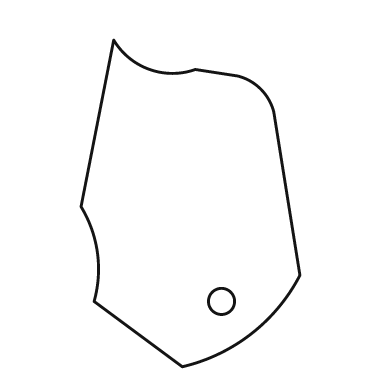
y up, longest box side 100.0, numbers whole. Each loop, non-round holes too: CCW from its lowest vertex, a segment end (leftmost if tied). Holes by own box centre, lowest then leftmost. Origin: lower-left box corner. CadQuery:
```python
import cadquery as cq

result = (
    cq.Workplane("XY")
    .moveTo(31.0, 0.0)
    .threePointArc((52.0, 10.0), (67.0, 28.0))
    .lineTo(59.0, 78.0)
    .threePointArc((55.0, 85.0), (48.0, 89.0))
    .lineTo(35.0, 91.0)
    .threePointArc((21.0, 91.0), (10.0, 100.0))
    .lineTo(0.0, 49.0)
    .threePointArc((5.0, 35.0), (4.0, 20.0))
    .close()
    .moveTo(43.0, 20.0)
    .circle(4.0)
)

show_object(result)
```